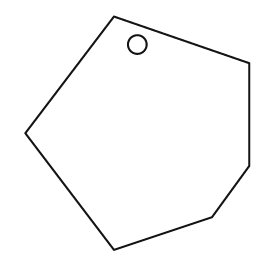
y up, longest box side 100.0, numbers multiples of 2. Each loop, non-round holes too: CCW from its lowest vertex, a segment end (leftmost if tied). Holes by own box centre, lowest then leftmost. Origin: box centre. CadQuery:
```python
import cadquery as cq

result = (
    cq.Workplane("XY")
    .moveTo(-10.0, -50.0)
    .lineTo(32.0, -36.0)
    .lineTo(48.0, -14.0)
    .lineTo(48.0, 30.0)
    .lineTo(-10.0, 50.0)
    .lineTo(-48.0, 0.0)
    .close()
    .moveTo(0.0, 38.0)
    .circle(4.0)
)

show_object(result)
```